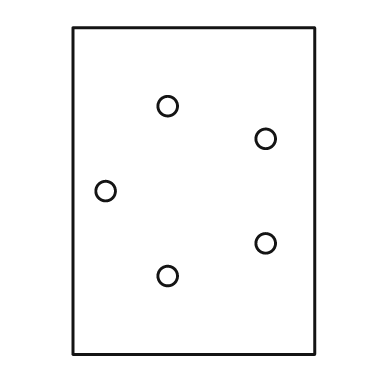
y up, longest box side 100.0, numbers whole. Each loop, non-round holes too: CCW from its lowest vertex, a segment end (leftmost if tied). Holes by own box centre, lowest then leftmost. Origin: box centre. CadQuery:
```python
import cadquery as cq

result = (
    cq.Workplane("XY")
    .moveTo(-37.0, -50.0)
    .lineTo(37.0, -50.0)
    .lineTo(37.0, 50.0)
    .lineTo(-37.0, 50.0)
    .close()
    .moveTo(-8.0, -26.0)
    .circle(3.0)
    .moveTo(22.0, -16.0)
    .circle(3.0)
    .moveTo(-27.0, 0.0)
    .circle(3.0)
    .moveTo(22.0, 16.0)
    .circle(3.0)
    .moveTo(-8.0, 26.0)
    .circle(3.0)
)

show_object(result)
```